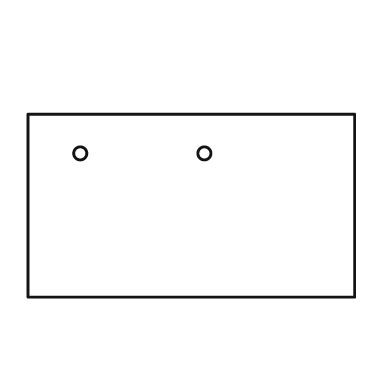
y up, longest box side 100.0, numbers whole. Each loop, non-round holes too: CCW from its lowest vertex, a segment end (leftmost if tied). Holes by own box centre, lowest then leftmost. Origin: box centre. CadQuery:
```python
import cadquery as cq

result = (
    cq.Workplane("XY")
    .moveTo(-50.0, -28.0)
    .lineTo(50.0, -28.0)
    .lineTo(50.0, 28.0)
    .lineTo(-50.0, 28.0)
    .close()
    .moveTo(-34.0, 16.0)
    .circle(2.0)
    .moveTo(4.0, 16.0)
    .circle(2.0)
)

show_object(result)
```